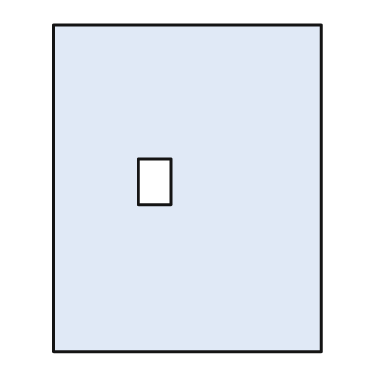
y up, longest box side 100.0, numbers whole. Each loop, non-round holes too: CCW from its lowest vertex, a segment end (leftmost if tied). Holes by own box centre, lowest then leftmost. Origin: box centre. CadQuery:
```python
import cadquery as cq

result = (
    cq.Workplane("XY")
    .moveTo(-41.0, -50.0)
    .lineTo(41.0, -50.0)
    .lineTo(41.0, 50.0)
    .lineTo(-41.0, 50.0)
    .close()
    .moveTo(-15.0, -5.0)
    .lineTo(-5.0, -5.0)
    .lineTo(-5.0, 9.0)
    .lineTo(-15.0, 9.0)
    .close()
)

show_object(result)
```